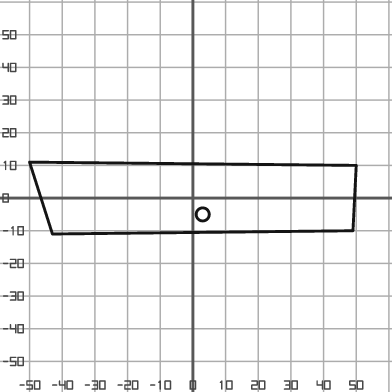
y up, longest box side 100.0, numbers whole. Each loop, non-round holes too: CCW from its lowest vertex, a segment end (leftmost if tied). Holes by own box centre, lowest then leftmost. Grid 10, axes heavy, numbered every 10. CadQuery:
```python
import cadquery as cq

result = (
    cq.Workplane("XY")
    .moveTo(-43.0, -11.0)
    .lineTo(49.0, -10.0)
    .lineTo(50.0, 10.0)
    .lineTo(-50.0, 11.0)
    .close()
    .moveTo(3.0, -5.0)
    .circle(2.0)
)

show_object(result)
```